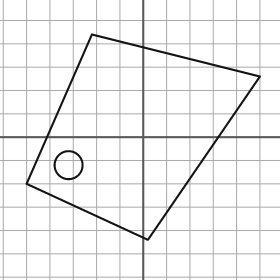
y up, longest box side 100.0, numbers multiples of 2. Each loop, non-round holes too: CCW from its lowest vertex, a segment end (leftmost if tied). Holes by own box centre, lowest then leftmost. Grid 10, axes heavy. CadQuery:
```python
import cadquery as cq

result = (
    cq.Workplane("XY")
    .moveTo(2.0, -44.0)
    .lineTo(50.0, 26.0)
    .lineTo(-22.0, 44.0)
    .lineTo(-50.0, -20.0)
    .close()
    .moveTo(-32.0, -12.0)
    .circle(6.0)
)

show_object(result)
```